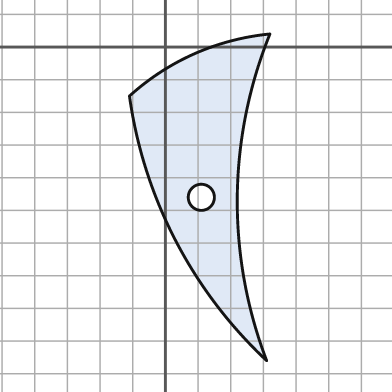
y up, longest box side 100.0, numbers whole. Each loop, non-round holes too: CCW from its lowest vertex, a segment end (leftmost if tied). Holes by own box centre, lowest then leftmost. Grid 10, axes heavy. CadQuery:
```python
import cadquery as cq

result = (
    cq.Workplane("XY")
    .moveTo(31.0, -96.0)
    .threePointArc((22.0, -46.0), (32.0, 4.0))
    .threePointArc((9.0, -2.0), (-11.0, -15.0))
    .threePointArc((3.0, -59.0), (31.0, -96.0))
    .close()
    .moveTo(11.0, -46.0)
    .circle(4.0)
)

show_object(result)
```